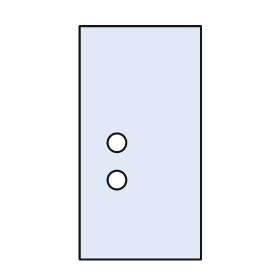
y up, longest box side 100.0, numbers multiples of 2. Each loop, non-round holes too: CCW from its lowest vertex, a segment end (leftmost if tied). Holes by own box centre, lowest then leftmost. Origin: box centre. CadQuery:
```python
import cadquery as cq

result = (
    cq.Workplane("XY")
    .moveTo(-26.0, -50.0)
    .lineTo(26.0, -50.0)
    .lineTo(26.0, 50.0)
    .lineTo(-26.0, 50.0)
    .close()
    .moveTo(-10.0, -16.0)
    .circle(4.0)
    .moveTo(-10.0, 0.0)
    .circle(4.0)
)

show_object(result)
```